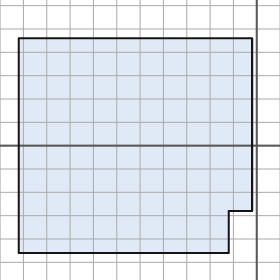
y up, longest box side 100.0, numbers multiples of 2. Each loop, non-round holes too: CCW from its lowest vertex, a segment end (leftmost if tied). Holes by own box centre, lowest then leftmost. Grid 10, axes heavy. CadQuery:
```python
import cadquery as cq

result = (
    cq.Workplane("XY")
    .moveTo(-102.0, -46.0)
    .lineTo(-12.0, -46.0)
    .lineTo(-12.0, -28.0)
    .lineTo(-2.0, -28.0)
    .lineTo(-2.0, 46.0)
    .lineTo(-102.0, 46.0)
    .close()
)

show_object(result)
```